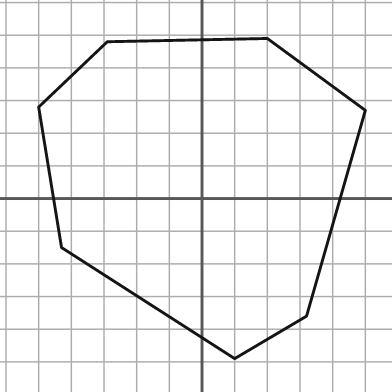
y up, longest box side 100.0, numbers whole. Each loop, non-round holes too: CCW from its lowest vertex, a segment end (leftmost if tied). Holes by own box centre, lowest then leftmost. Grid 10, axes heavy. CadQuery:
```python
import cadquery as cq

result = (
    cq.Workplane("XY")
    .moveTo(10.0, -49.0)
    .lineTo(32.0, -36.0)
    .lineTo(50.0, 27.0)
    .lineTo(20.0, 49.0)
    .lineTo(-29.0, 48.0)
    .lineTo(-50.0, 28.0)
    .lineTo(-43.0, -15.0)
    .close()
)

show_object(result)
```